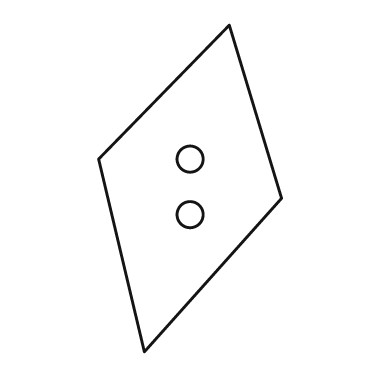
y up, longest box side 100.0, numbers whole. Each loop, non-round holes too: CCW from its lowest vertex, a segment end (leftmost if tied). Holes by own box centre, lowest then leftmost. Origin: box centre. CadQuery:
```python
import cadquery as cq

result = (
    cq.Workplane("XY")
    .moveTo(-14.0, -50.0)
    .lineTo(28.0, -3.0)
    .lineTo(12.0, 50.0)
    .lineTo(-28.0, 9.0)
    .close()
    .moveTo(0.0, -8.0)
    .circle(4.0)
    .moveTo(0.0, 9.0)
    .circle(4.0)
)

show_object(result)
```